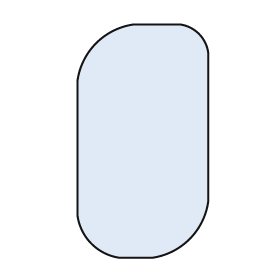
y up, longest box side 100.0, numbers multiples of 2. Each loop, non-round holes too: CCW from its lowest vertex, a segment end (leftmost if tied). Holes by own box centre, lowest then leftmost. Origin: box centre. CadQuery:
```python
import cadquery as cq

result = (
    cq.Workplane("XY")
    .moveTo(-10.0, -50.0)
    .lineTo(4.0, -50.0)
    .threePointArc((20.0, -42.0), (28.0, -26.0))
    .lineTo(28.0, 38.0)
    .threePointArc((24.0, 46.0), (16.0, 50.0))
    .lineTo(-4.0, 50.0)
    .threePointArc((-20.0, 42.0), (-28.0, 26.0))
    .lineTo(-28.0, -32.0)
    .threePointArc((-22.0, -44.0), (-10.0, -50.0))
    .close()
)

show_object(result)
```